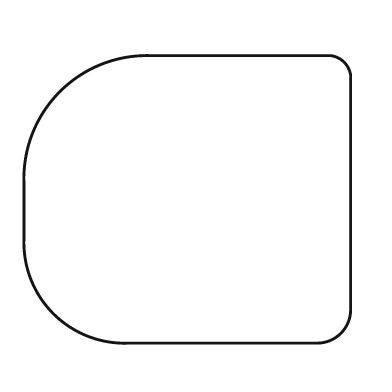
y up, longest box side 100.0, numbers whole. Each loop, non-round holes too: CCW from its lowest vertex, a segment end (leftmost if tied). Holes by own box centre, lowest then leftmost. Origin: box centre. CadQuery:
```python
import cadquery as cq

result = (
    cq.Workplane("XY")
    .moveTo(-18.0, -44.0)
    .lineTo(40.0, -44.0)
    .threePointArc((47.0, -41.0), (50.0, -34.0))
    .lineTo(50.0, 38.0)
    .threePointArc((48.0, 42.0), (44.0, 44.0))
    .lineTo(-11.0, 44.0)
    .threePointArc((-39.0, 33.0), (-50.0, 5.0))
    .lineTo(-50.0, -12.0)
    .threePointArc((-41.0, -35.0), (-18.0, -44.0))
    .close()
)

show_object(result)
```